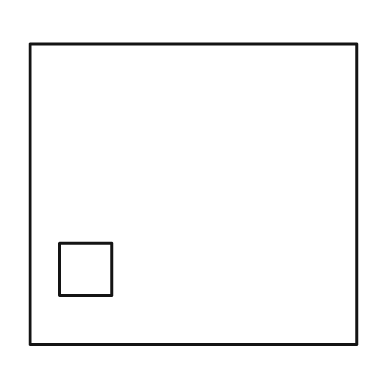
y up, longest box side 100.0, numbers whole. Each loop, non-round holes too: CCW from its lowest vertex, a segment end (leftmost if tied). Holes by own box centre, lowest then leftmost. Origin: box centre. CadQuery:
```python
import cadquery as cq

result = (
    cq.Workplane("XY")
    .moveTo(-50.0, -46.0)
    .lineTo(50.0, -46.0)
    .lineTo(50.0, 46.0)
    .lineTo(-50.0, 46.0)
    .close()
    .moveTo(-41.0, -31.0)
    .lineTo(-25.0, -31.0)
    .lineTo(-25.0, -15.0)
    .lineTo(-41.0, -15.0)
    .close()
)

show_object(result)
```